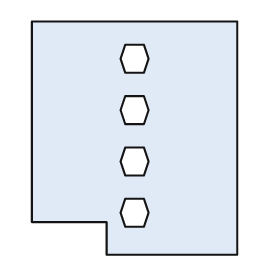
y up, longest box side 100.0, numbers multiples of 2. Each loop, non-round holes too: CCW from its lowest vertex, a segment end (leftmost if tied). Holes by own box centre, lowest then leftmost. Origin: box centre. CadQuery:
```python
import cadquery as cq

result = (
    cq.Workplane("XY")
    .moveTo(-12.0, -50.0)
    .lineTo(44.0, -50.0)
    .lineTo(44.0, 50.0)
    .lineTo(-44.0, 50.0)
    .lineTo(-44.0, -36.0)
    .lineTo(-12.0, -36.0)
    .close()
    .moveTo(-4.0, -38.0)
    .lineTo(4.0, -38.0)
    .lineTo(6.0, -32.0)
    .lineTo(4.0, -26.0)
    .lineTo(-4.0, -26.0)
    .lineTo(-6.0, -32.0)
    .close()
    .moveTo(-4.0, -16.0)
    .lineTo(4.0, -16.0)
    .lineTo(6.0, -10.0)
    .lineTo(4.0, -4.0)
    .lineTo(-4.0, -4.0)
    .lineTo(-6.0, -10.0)
    .close()
    .moveTo(-4.0, 6.0)
    .lineTo(4.0, 6.0)
    .lineTo(6.0, 12.0)
    .lineTo(4.0, 18.0)
    .lineTo(-4.0, 18.0)
    .lineTo(-6.0, 12.0)
    .close()
    .moveTo(-4.0, 28.0)
    .lineTo(4.0, 28.0)
    .lineTo(6.0, 34.0)
    .lineTo(4.0, 40.0)
    .lineTo(-4.0, 40.0)
    .lineTo(-6.0, 34.0)
    .close()
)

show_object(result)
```